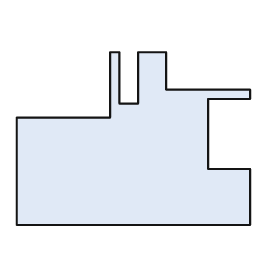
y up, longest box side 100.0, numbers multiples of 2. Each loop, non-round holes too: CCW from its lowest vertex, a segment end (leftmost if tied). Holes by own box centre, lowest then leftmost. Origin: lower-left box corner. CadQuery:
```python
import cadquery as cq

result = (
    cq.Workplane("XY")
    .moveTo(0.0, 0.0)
    .lineTo(100.0, 0.0)
    .lineTo(100.0, 24.0)
    .lineTo(82.0, 24.0)
    .lineTo(82.0, 54.0)
    .lineTo(100.0, 54.0)
    .lineTo(100.0, 58.0)
    .lineTo(64.0, 58.0)
    .lineTo(64.0, 74.0)
    .lineTo(52.0, 74.0)
    .lineTo(52.0, 52.0)
    .lineTo(44.0, 52.0)
    .lineTo(44.0, 74.0)
    .lineTo(40.0, 74.0)
    .lineTo(40.0, 46.0)
    .lineTo(0.0, 46.0)
    .close()
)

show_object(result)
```